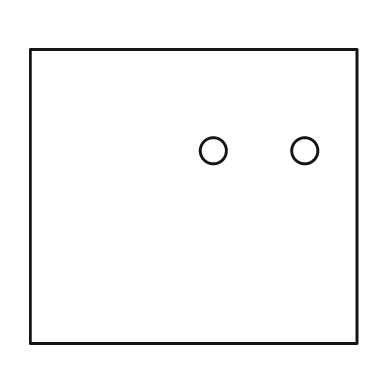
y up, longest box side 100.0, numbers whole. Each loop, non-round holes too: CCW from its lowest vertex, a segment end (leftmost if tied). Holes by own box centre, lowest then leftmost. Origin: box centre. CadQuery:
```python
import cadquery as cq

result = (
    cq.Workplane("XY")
    .moveTo(-50.0, -45.0)
    .lineTo(50.0, -45.0)
    .lineTo(50.0, 45.0)
    .lineTo(-50.0, 45.0)
    .close()
    .moveTo(6.0, 14.0)
    .circle(4.0)
    .moveTo(34.0, 14.0)
    .circle(4.0)
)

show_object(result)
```